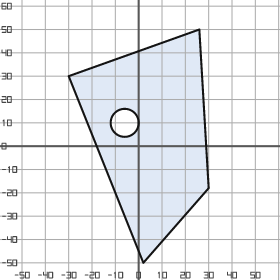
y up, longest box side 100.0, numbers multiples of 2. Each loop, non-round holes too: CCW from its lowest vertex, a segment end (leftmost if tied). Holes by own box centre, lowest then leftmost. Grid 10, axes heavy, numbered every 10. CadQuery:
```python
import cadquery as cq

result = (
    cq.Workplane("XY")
    .moveTo(2.0, -50.0)
    .lineTo(30.0, -18.0)
    .lineTo(26.0, 50.0)
    .lineTo(-30.0, 30.0)
    .close()
    .moveTo(-6.0, 10.0)
    .circle(6.0)
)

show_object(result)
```